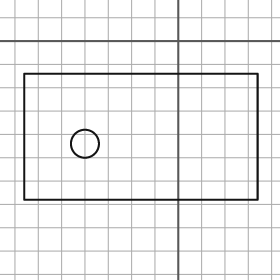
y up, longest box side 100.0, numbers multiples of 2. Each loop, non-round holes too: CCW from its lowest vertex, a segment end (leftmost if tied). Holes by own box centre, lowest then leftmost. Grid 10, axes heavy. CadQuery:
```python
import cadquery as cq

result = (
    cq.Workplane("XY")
    .moveTo(-66.0, -68.0)
    .lineTo(34.0, -68.0)
    .lineTo(34.0, -14.0)
    .lineTo(-66.0, -14.0)
    .close()
    .moveTo(-40.0, -44.0)
    .circle(6.0)
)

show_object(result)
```